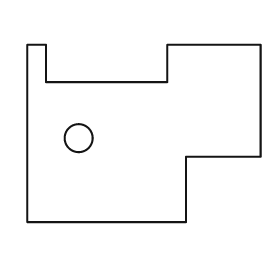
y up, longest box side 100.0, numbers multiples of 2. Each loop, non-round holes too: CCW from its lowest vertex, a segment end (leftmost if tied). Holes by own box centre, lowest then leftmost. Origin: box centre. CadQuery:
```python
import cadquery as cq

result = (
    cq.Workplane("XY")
    .moveTo(-50.0, -38.0)
    .lineTo(18.0, -38.0)
    .lineTo(18.0, -10.0)
    .lineTo(50.0, -10.0)
    .lineTo(50.0, 38.0)
    .lineTo(10.0, 38.0)
    .lineTo(10.0, 22.0)
    .lineTo(-42.0, 22.0)
    .lineTo(-42.0, 38.0)
    .lineTo(-50.0, 38.0)
    .close()
    .moveTo(-28.0, -2.0)
    .circle(6.0)
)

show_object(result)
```